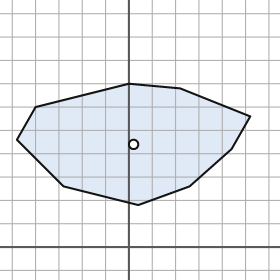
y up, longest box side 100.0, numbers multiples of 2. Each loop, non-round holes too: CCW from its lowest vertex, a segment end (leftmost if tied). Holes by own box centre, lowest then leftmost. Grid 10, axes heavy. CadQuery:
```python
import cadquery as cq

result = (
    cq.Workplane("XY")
    .moveTo(4.0, 18.0)
    .lineTo(26.0, 26.0)
    .lineTo(44.0, 42.0)
    .lineTo(52.0, 56.0)
    .lineTo(22.0, 68.0)
    .lineTo(0.0, 70.0)
    .lineTo(-40.0, 60.0)
    .lineTo(-48.0, 46.0)
    .lineTo(-28.0, 26.0)
    .close()
    .moveTo(2.0, 44.0)
    .circle(2.0)
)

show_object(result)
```